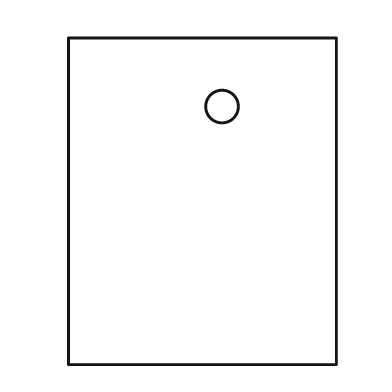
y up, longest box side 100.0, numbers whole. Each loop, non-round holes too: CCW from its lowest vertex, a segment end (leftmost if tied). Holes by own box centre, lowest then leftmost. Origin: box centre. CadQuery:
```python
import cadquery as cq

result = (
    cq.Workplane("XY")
    .moveTo(-41.0, -50.0)
    .lineTo(41.0, -50.0)
    .lineTo(41.0, 50.0)
    .lineTo(-41.0, 50.0)
    .close()
    .moveTo(6.0, 29.0)
    .circle(5.0)
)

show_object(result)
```